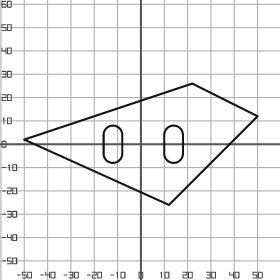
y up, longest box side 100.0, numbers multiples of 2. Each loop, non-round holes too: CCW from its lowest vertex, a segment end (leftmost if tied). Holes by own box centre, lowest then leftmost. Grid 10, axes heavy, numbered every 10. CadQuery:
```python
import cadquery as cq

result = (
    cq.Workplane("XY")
    .moveTo(12.0, -26.0)
    .lineTo(50.0, 12.0)
    .lineTo(22.0, 26.0)
    .lineTo(-50.0, 2.0)
    .close()
    .moveTo(-16.0, -4.0)
    .threePointArc((-12.0, -8.0), (-8.0, -4.0))
    .lineTo(-8.0, 4.0)
    .threePointArc((-12.0, 8.0), (-16.0, 4.0))
    .close()
    .moveTo(10.0, -4.0)
    .threePointArc((14.0, -8.0), (18.0, -4.0))
    .lineTo(18.0, 4.0)
    .threePointArc((14.0, 8.0), (10.0, 4.0))
    .close()
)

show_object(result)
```